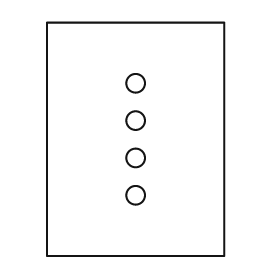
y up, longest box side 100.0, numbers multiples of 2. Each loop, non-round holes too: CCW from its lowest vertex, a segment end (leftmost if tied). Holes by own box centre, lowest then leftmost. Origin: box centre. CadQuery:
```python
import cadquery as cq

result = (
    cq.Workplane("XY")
    .moveTo(-38.0, -50.0)
    .lineTo(38.0, -50.0)
    .lineTo(38.0, 50.0)
    .lineTo(-38.0, 50.0)
    .close()
    .moveTo(0.0, -24.0)
    .circle(4.0)
    .moveTo(0.0, -8.0)
    .circle(4.0)
    .moveTo(0.0, 8.0)
    .circle(4.0)
    .moveTo(0.0, 24.0)
    .circle(4.0)
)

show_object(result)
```